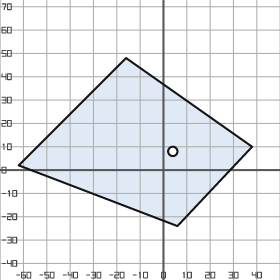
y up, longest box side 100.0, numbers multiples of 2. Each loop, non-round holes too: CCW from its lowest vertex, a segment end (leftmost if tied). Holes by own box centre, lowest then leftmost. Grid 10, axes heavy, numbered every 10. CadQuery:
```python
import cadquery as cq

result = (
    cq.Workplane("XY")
    .moveTo(6.0, -24.0)
    .lineTo(38.0, 10.0)
    .lineTo(-16.0, 48.0)
    .lineTo(-62.0, 2.0)
    .close()
    .moveTo(4.0, 8.0)
    .circle(2.0)
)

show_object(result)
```